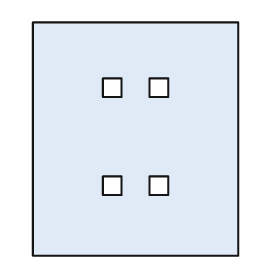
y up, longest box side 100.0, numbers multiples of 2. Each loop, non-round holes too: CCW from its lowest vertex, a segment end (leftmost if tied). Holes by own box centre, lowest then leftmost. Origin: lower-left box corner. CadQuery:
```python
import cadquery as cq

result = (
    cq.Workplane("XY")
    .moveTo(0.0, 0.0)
    .lineTo(88.0, 0.0)
    .lineTo(88.0, 100.0)
    .lineTo(0.0, 100.0)
    .close()
    .moveTo(30.0, 26.0)
    .lineTo(38.0, 26.0)
    .lineTo(38.0, 34.0)
    .lineTo(30.0, 34.0)
    .close()
    .moveTo(50.0, 26.0)
    .lineTo(58.0, 26.0)
    .lineTo(58.0, 34.0)
    .lineTo(50.0, 34.0)
    .close()
    .moveTo(30.0, 68.0)
    .lineTo(38.0, 68.0)
    .lineTo(38.0, 76.0)
    .lineTo(30.0, 76.0)
    .close()
    .moveTo(50.0, 68.0)
    .lineTo(58.0, 68.0)
    .lineTo(58.0, 76.0)
    .lineTo(50.0, 76.0)
    .close()
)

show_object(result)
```